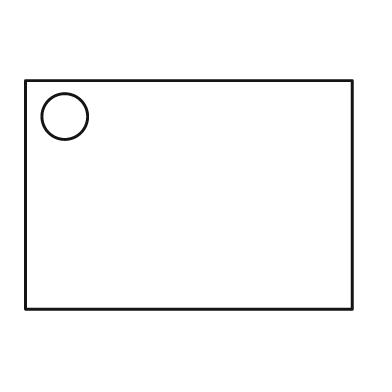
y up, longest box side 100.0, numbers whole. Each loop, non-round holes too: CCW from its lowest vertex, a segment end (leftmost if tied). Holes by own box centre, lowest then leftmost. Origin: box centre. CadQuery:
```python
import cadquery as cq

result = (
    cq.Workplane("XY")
    .moveTo(-50.0, -35.0)
    .lineTo(50.0, -35.0)
    .lineTo(50.0, 35.0)
    .lineTo(-50.0, 35.0)
    .close()
    .moveTo(-38.0, 24.0)
    .circle(7.0)
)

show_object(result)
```